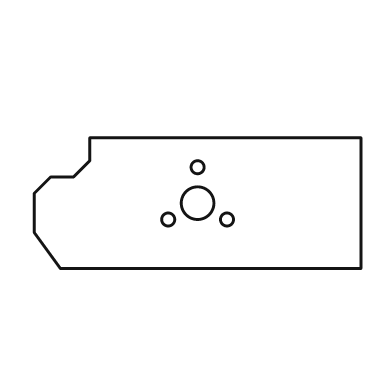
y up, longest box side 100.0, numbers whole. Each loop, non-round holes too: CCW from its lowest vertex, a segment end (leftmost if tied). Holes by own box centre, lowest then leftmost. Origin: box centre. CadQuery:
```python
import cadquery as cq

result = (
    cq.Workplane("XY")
    .moveTo(-42.0, -20.0)
    .lineTo(50.0, -20.0)
    .lineTo(50.0, 20.0)
    .lineTo(-33.0, 20.0)
    .lineTo(-33.0, 13.0)
    .lineTo(-38.0, 8.0)
    .lineTo(-45.0, 8.0)
    .lineTo(-50.0, 3.0)
    .lineTo(-50.0, -9.0)
    .close()
    .moveTo(-9.0, -5.0)
    .circle(2.0)
    .moveTo(9.0, -5.0)
    .circle(2.0)
    .moveTo(0.0, 0.0)
    .circle(5.0)
    .moveTo(0.0, 11.0)
    .circle(2.0)
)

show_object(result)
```